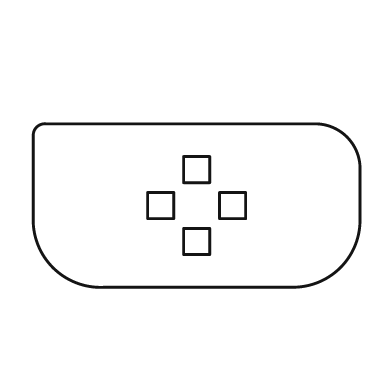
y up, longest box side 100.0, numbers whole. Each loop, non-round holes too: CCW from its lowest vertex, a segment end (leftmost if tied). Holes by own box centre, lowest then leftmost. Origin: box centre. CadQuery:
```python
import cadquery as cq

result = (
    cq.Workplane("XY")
    .moveTo(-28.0, -25.0)
    .lineTo(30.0, -25.0)
    .threePointArc((44.0, -19.0), (50.0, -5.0))
    .lineTo(50.0, 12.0)
    .threePointArc((46.0, 21.0), (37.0, 25.0))
    .lineTo(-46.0, 25.0)
    .threePointArc((-49.0, 24.0), (-50.0, 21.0))
    .lineTo(-50.0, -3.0)
    .threePointArc((-44.0, -19.0), (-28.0, -25.0))
    .close()
    .moveTo(-4.0, -15.0)
    .lineTo(4.0, -15.0)
    .lineTo(4.0, -7.0)
    .lineTo(-4.0, -7.0)
    .close()
    .moveTo(-15.0, -4.0)
    .lineTo(-7.0, -4.0)
    .lineTo(-7.0, 4.0)
    .lineTo(-15.0, 4.0)
    .close()
    .moveTo(7.0, -4.0)
    .lineTo(15.0, -4.0)
    .lineTo(15.0, 4.0)
    .lineTo(7.0, 4.0)
    .close()
    .moveTo(-4.0, 7.0)
    .lineTo(4.0, 7.0)
    .lineTo(4.0, 15.0)
    .lineTo(-4.0, 15.0)
    .close()
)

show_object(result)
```